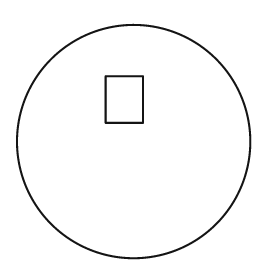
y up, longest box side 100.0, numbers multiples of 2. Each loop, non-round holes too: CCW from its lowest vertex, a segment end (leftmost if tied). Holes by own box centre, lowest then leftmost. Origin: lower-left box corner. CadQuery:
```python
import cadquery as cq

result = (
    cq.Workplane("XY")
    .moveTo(50.0, 50.0)
    .circle(50.0)
    .moveTo(38.0, 58.0)
    .lineTo(54.0, 58.0)
    .lineTo(54.0, 78.0)
    .lineTo(38.0, 78.0)
    .close()
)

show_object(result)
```